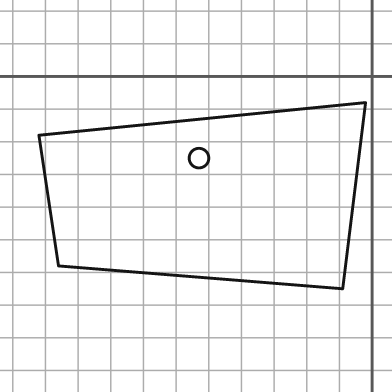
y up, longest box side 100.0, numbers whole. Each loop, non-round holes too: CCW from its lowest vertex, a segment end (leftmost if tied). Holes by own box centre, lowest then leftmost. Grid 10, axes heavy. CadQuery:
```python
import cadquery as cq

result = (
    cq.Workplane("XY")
    .moveTo(-9.0, -65.0)
    .lineTo(-2.0, -8.0)
    .lineTo(-102.0, -18.0)
    .lineTo(-96.0, -58.0)
    .close()
    .moveTo(-53.0, -25.0)
    .circle(3.0)
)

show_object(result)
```